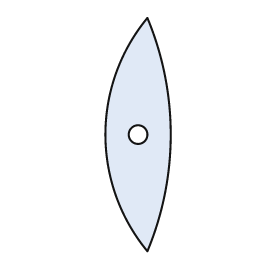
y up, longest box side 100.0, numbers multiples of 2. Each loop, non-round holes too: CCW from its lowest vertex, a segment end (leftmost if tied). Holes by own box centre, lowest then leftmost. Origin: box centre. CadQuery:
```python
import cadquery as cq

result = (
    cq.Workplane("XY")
    .moveTo(4.0, -50.0)
    .threePointArc((14.0, 0.0), (4.0, 50.0))
    .threePointArc((-14.0, 0.0), (4.0, -50.0))
    .close()
    .moveTo(0.0, 0.0)
    .circle(4.0)
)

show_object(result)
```